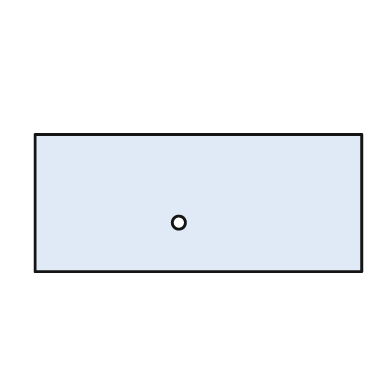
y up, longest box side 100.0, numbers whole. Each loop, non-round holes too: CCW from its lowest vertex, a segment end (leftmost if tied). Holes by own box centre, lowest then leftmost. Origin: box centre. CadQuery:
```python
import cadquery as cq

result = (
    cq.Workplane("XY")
    .moveTo(-50.0, -21.0)
    .lineTo(50.0, -21.0)
    .lineTo(50.0, 21.0)
    .lineTo(-50.0, 21.0)
    .close()
    .moveTo(-6.0, -6.0)
    .circle(2.0)
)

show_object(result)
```